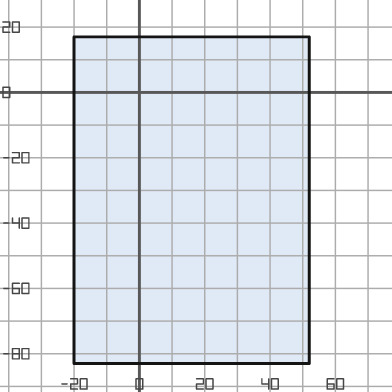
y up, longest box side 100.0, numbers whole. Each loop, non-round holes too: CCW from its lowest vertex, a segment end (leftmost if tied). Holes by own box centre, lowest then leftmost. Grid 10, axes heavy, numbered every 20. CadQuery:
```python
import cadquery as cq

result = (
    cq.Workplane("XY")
    .moveTo(-20.0, -83.0)
    .lineTo(52.0, -83.0)
    .lineTo(52.0, 17.0)
    .lineTo(-20.0, 17.0)
    .close()
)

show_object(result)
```